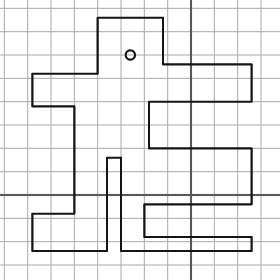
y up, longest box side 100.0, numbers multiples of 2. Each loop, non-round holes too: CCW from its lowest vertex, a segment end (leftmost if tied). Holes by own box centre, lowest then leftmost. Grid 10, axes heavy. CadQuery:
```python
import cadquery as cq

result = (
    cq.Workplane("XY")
    .moveTo(-68.0, -24.0)
    .lineTo(-36.0, -24.0)
    .lineTo(-36.0, 16.0)
    .lineTo(-30.0, 16.0)
    .lineTo(-30.0, -24.0)
    .lineTo(26.0, -24.0)
    .lineTo(26.0, -18.0)
    .lineTo(-20.0, -18.0)
    .lineTo(-20.0, -4.0)
    .lineTo(26.0, -4.0)
    .lineTo(26.0, 20.0)
    .lineTo(-18.0, 20.0)
    .lineTo(-18.0, 40.0)
    .lineTo(26.0, 40.0)
    .lineTo(26.0, 56.0)
    .lineTo(-12.0, 56.0)
    .lineTo(-12.0, 76.0)
    .lineTo(-40.0, 76.0)
    .lineTo(-40.0, 52.0)
    .lineTo(-68.0, 52.0)
    .lineTo(-68.0, 38.0)
    .lineTo(-50.0, 38.0)
    .lineTo(-50.0, -8.0)
    .lineTo(-68.0, -8.0)
    .close()
    .moveTo(-26.0, 60.0)
    .circle(2.0)
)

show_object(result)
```